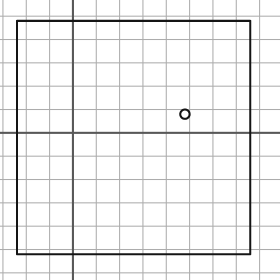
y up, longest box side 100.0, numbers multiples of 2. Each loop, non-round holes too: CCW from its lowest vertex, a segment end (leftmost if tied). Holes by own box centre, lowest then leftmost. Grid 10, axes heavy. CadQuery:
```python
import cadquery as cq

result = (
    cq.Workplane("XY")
    .moveTo(-24.0, -52.0)
    .lineTo(76.0, -52.0)
    .lineTo(76.0, 48.0)
    .lineTo(-24.0, 48.0)
    .close()
    .moveTo(48.0, 8.0)
    .circle(2.0)
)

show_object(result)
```